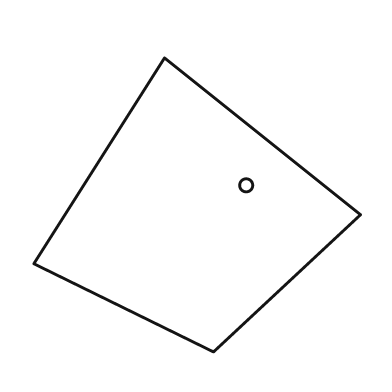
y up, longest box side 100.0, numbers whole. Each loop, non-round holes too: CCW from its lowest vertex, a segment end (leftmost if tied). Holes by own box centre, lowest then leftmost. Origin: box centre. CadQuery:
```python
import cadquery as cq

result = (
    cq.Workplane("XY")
    .moveTo(5.0, -45.0)
    .lineTo(50.0, -3.0)
    .lineTo(-10.0, 45.0)
    .lineTo(-50.0, -18.0)
    .close()
    .moveTo(15.0, 6.0)
    .circle(2.0)
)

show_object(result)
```